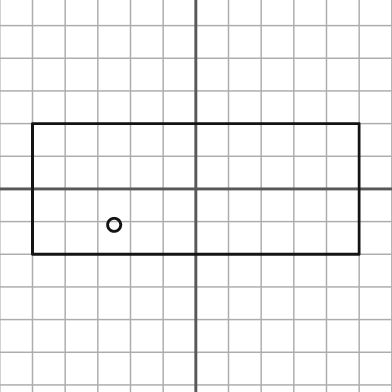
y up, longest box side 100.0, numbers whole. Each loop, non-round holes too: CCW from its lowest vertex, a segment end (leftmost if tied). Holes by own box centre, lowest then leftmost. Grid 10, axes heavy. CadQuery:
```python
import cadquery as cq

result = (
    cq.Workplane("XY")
    .moveTo(-50.0, -20.0)
    .lineTo(50.0, -20.0)
    .lineTo(50.0, 20.0)
    .lineTo(-50.0, 20.0)
    .close()
    .moveTo(-25.0, -11.0)
    .circle(2.0)
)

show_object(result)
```